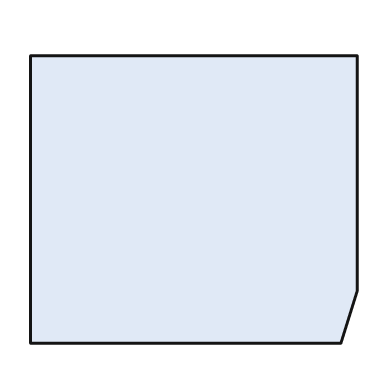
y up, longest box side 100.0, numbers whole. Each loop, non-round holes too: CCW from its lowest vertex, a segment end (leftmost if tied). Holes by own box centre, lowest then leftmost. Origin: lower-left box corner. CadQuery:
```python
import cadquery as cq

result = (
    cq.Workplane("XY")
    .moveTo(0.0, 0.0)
    .lineTo(95.0, 0.0)
    .lineTo(100.0, 16.0)
    .lineTo(100.0, 88.0)
    .lineTo(0.0, 88.0)
    .close()
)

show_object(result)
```